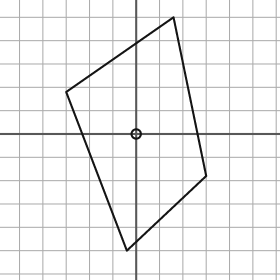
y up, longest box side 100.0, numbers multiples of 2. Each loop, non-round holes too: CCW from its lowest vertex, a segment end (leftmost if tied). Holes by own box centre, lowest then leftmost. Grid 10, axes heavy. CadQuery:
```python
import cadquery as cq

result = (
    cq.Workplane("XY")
    .moveTo(-4.0, -50.0)
    .lineTo(30.0, -18.0)
    .lineTo(16.0, 50.0)
    .lineTo(-30.0, 18.0)
    .close()
    .moveTo(0.0, 0.0)
    .circle(2.0)
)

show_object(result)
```